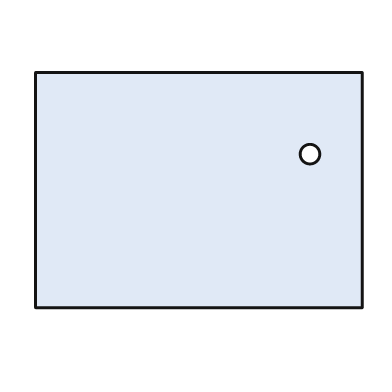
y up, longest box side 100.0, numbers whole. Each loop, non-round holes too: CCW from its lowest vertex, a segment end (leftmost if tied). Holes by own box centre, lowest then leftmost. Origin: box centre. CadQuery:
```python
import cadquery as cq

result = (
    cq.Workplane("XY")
    .moveTo(-50.0, -36.0)
    .lineTo(50.0, -36.0)
    .lineTo(50.0, 36.0)
    .lineTo(-50.0, 36.0)
    .close()
    .moveTo(34.0, 11.0)
    .circle(3.0)
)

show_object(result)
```